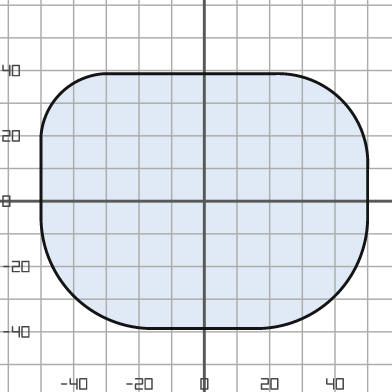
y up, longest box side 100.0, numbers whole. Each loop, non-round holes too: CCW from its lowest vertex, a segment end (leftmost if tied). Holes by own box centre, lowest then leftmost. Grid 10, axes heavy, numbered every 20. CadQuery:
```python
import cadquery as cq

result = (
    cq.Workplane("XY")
    .moveTo(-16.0, -39.0)
    .lineTo(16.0, -39.0)
    .threePointArc((40.0, -29.0), (50.0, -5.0))
    .lineTo(50.0, 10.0)
    .threePointArc((42.0, 31.0), (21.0, 39.0))
    .lineTo(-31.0, 39.0)
    .threePointArc((-44.0, 33.0), (-50.0, 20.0))
    .lineTo(-50.0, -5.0)
    .threePointArc((-40.0, -29.0), (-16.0, -39.0))
    .close()
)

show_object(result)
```